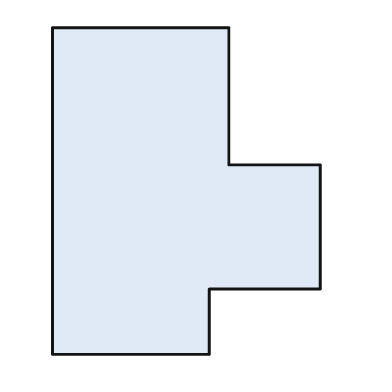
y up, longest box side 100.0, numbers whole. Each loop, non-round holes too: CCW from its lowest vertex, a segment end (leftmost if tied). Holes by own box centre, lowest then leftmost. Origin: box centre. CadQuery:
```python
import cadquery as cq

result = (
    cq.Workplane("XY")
    .moveTo(-41.0, -50.0)
    .lineTo(7.0, -50.0)
    .lineTo(7.0, -30.0)
    .lineTo(41.0, -30.0)
    .lineTo(41.0, 8.0)
    .lineTo(13.0, 8.0)
    .lineTo(13.0, 50.0)
    .lineTo(-41.0, 50.0)
    .close()
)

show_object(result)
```